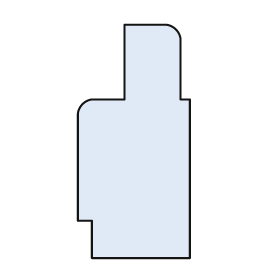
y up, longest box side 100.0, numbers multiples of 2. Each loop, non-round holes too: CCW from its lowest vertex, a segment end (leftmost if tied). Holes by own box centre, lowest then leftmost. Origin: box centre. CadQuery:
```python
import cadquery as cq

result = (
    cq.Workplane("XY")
    .moveTo(-18.0, -50.0)
    .lineTo(24.0, -50.0)
    .lineTo(24.0, 18.0)
    .lineTo(20.0, 18.0)
    .lineTo(20.0, 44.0)
    .threePointArc((18.0, 48.0), (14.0, 50.0))
    .lineTo(-4.0, 50.0)
    .lineTo(-4.0, 18.0)
    .lineTo(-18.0, 18.0)
    .threePointArc((-22.0, 16.0), (-24.0, 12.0))
    .lineTo(-24.0, -34.0)
    .lineTo(-18.0, -34.0)
    .close()
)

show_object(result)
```